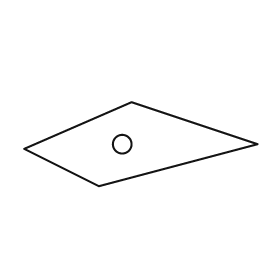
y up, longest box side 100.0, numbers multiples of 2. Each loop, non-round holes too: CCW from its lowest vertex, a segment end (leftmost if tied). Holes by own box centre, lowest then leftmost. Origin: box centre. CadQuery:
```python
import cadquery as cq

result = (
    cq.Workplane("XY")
    .moveTo(-18.0, -18.0)
    .lineTo(50.0, 0.0)
    .lineTo(-4.0, 18.0)
    .lineTo(-50.0, -2.0)
    .close()
    .moveTo(-8.0, 0.0)
    .circle(4.0)
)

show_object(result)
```